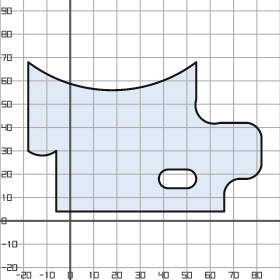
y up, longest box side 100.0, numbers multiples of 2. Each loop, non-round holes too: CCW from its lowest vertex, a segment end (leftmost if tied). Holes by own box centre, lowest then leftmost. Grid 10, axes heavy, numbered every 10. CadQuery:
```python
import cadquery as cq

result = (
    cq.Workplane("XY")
    .moveTo(-6.0, 4.0)
    .lineTo(66.0, 4.0)
    .lineTo(66.0, 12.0)
    .threePointArc((68.0, 16.0), (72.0, 18.0))
    .lineTo(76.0, 18.0)
    .threePointArc((80.0, 20.0), (82.0, 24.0))
    .lineTo(82.0, 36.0)
    .threePointArc((80.0, 40.0), (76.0, 42.0))
    .lineTo(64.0, 42.0)
    .threePointArc((56.0, 44.0), (54.0, 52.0))
    .lineTo(54.0, 68.0)
    .threePointArc((18.0, 56.0), (-18.0, 68.0))
    .lineTo(-18.0, 30.0)
    .threePointArc((-12.0, 28.0), (-6.0, 30.0))
    .close()
    .moveTo(42.0, 14.0)
    .lineTo(50.0, 14.0)
    .threePointArc((54.0, 18.0), (50.0, 22.0))
    .lineTo(42.0, 22.0)
    .threePointArc((38.0, 18.0), (42.0, 14.0))
    .close()
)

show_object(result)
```